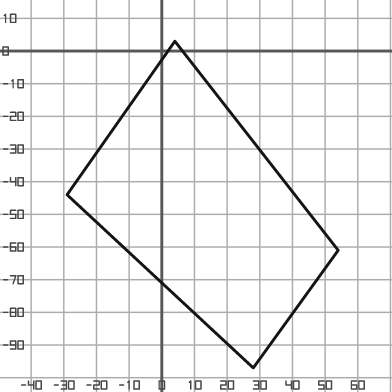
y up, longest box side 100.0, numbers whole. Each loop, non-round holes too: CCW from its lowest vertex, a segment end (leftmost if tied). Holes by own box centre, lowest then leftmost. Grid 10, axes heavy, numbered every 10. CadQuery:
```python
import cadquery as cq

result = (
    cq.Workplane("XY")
    .moveTo(28.0, -97.0)
    .lineTo(54.0, -61.0)
    .lineTo(4.0, 3.0)
    .lineTo(-29.0, -44.0)
    .close()
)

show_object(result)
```